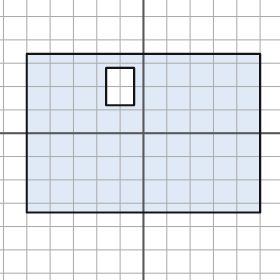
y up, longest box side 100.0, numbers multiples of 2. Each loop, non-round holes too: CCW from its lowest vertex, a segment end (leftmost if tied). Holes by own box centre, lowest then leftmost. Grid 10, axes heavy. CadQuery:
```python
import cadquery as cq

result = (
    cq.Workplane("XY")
    .moveTo(-50.0, -34.0)
    .lineTo(50.0, -34.0)
    .lineTo(50.0, 34.0)
    .lineTo(-50.0, 34.0)
    .close()
    .moveTo(-16.0, 12.0)
    .lineTo(-4.0, 12.0)
    .lineTo(-4.0, 28.0)
    .lineTo(-16.0, 28.0)
    .close()
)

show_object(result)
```